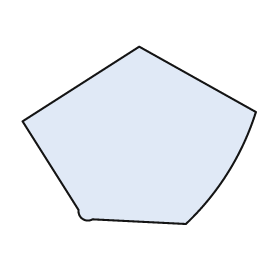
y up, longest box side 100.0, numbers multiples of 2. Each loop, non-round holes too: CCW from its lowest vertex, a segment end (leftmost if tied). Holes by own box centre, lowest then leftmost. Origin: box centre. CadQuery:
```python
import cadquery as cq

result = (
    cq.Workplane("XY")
    .moveTo(20.0, -38.0)
    .threePointArc((38.0, -16.0), (50.0, 10.0))
    .lineTo(0.0, 38.0)
    .lineTo(-50.0, 6.0)
    .lineTo(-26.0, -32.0)
    .threePointArc((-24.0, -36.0), (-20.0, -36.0))
    .close()
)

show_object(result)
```